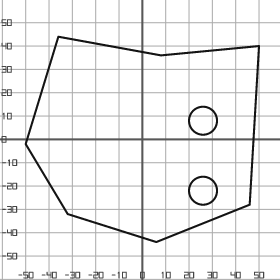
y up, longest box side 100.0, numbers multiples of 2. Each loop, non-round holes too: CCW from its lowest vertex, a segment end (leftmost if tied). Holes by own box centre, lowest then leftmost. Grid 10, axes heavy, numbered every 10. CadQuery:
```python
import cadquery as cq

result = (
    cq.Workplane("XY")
    .moveTo(6.0, -44.0)
    .lineTo(46.0, -28.0)
    .lineTo(50.0, 40.0)
    .lineTo(8.0, 36.0)
    .lineTo(-36.0, 44.0)
    .lineTo(-50.0, -2.0)
    .lineTo(-32.0, -32.0)
    .close()
    .moveTo(26.0, -22.0)
    .circle(6.0)
    .moveTo(26.0, 8.0)
    .circle(6.0)
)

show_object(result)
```